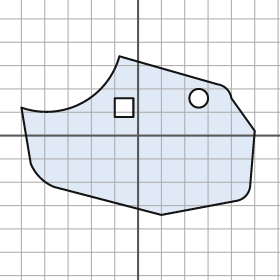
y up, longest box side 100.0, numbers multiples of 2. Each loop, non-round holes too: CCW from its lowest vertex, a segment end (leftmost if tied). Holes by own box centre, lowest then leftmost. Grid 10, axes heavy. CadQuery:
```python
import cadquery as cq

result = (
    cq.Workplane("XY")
    .moveTo(10.0, -34.0)
    .lineTo(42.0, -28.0)
    .threePointArc((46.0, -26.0), (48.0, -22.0))
    .lineTo(50.0, 2.0)
    .lineTo(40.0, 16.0)
    .threePointArc((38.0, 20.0), (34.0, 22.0))
    .lineTo(-8.0, 34.0)
    .threePointArc((-24.0, 14.0), (-50.0, 12.0))
    .lineTo(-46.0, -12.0)
    .threePointArc((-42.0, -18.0), (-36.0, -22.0))
    .close()
    .moveTo(-10.0, 8.0)
    .lineTo(-2.0, 8.0)
    .lineTo(-2.0, 16.0)
    .lineTo(-10.0, 16.0)
    .close()
    .moveTo(26.0, 16.0)
    .circle(4.0)
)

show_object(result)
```